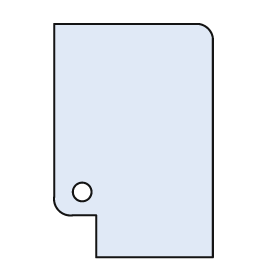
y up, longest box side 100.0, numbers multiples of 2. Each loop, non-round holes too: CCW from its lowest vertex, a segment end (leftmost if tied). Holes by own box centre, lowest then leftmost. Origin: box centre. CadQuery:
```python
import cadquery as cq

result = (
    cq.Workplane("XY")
    .moveTo(-16.0, -50.0)
    .lineTo(34.0, -50.0)
    .lineTo(34.0, 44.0)
    .threePointArc((32.0, 48.0), (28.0, 50.0))
    .lineTo(-34.0, 50.0)
    .lineTo(-34.0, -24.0)
    .threePointArc((-32.0, -30.0), (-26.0, -32.0))
    .lineTo(-16.0, -32.0)
    .close()
    .moveTo(-22.0, -22.0)
    .circle(4.0)
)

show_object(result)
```